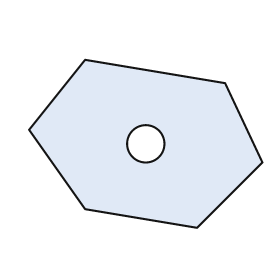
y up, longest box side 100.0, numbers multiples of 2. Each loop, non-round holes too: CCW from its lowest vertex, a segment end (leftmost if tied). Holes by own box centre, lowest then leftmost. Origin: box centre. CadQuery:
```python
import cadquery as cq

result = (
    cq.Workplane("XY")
    .moveTo(22.0, -36.0)
    .lineTo(50.0, -8.0)
    .lineTo(34.0, 26.0)
    .lineTo(-26.0, 36.0)
    .lineTo(-50.0, 6.0)
    .lineTo(-26.0, -28.0)
    .close()
    .moveTo(0.0, 0.0)
    .circle(8.0)
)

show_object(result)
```